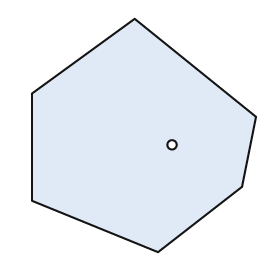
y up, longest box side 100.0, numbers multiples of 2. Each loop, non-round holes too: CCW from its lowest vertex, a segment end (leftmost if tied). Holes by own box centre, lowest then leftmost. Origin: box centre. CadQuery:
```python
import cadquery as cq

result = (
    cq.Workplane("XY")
    .moveTo(6.0, -50.0)
    .lineTo(42.0, -22.0)
    .lineTo(48.0, 8.0)
    .lineTo(-4.0, 50.0)
    .lineTo(-48.0, 18.0)
    .lineTo(-48.0, -28.0)
    .close()
    .moveTo(12.0, -4.0)
    .circle(2.0)
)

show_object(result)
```